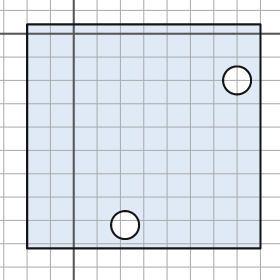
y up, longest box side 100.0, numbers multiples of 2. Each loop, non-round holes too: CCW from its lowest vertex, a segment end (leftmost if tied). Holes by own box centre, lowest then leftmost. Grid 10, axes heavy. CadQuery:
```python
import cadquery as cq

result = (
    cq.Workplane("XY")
    .moveTo(-20.0, -92.0)
    .lineTo(80.0, -92.0)
    .lineTo(80.0, 4.0)
    .lineTo(-20.0, 4.0)
    .close()
    .moveTo(22.0, -82.0)
    .circle(6.0)
    .moveTo(70.0, -20.0)
    .circle(6.0)
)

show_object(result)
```